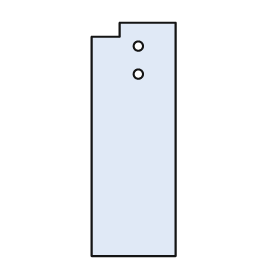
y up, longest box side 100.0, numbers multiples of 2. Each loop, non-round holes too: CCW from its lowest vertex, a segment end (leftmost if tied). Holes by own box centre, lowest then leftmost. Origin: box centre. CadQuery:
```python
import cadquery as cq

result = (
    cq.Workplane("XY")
    .moveTo(-18.0, -50.0)
    .lineTo(18.0, -50.0)
    .lineTo(18.0, 50.0)
    .lineTo(-6.0, 50.0)
    .lineTo(-6.0, 44.0)
    .lineTo(-18.0, 44.0)
    .close()
    .moveTo(2.0, 28.0)
    .circle(2.0)
    .moveTo(2.0, 40.0)
    .circle(2.0)
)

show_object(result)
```